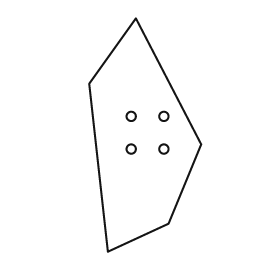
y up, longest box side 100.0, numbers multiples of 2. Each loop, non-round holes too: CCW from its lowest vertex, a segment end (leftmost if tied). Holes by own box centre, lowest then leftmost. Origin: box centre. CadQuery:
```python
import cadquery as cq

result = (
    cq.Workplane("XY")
    .moveTo(-16.0, -50.0)
    .lineTo(10.0, -38.0)
    .lineTo(24.0, -4.0)
    .lineTo(-4.0, 50.0)
    .lineTo(-24.0, 22.0)
    .close()
    .moveTo(-6.0, -6.0)
    .circle(2.0)
    .moveTo(8.0, -6.0)
    .circle(2.0)
    .moveTo(-6.0, 8.0)
    .circle(2.0)
    .moveTo(8.0, 8.0)
    .circle(2.0)
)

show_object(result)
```